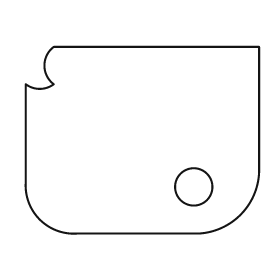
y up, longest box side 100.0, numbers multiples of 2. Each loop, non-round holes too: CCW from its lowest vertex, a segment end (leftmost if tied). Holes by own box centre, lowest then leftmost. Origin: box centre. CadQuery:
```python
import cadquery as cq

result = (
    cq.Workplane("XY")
    .moveTo(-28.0, -40.0)
    .lineTo(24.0, -40.0)
    .threePointArc((42.0, -32.0), (50.0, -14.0))
    .lineTo(50.0, 40.0)
    .lineTo(-38.0, 40.0)
    .threePointArc((-42.0, 32.0), (-38.0, 24.0))
    .threePointArc((-44.0, 22.0), (-50.0, 24.0))
    .lineTo(-50.0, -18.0)
    .threePointArc((-44.0, -34.0), (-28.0, -40.0))
    .close()
    .moveTo(22.0, -20.0)
    .circle(8.0)
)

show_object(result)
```